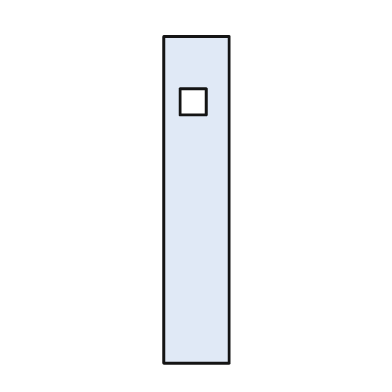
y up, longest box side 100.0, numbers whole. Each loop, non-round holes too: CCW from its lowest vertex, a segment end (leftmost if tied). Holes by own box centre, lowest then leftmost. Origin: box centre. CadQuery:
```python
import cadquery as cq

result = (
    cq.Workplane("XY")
    .moveTo(-10.0, -50.0)
    .lineTo(10.0, -50.0)
    .lineTo(10.0, 50.0)
    .lineTo(-10.0, 50.0)
    .close()
    .moveTo(-5.0, 26.0)
    .lineTo(3.0, 26.0)
    .lineTo(3.0, 34.0)
    .lineTo(-5.0, 34.0)
    .close()
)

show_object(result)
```